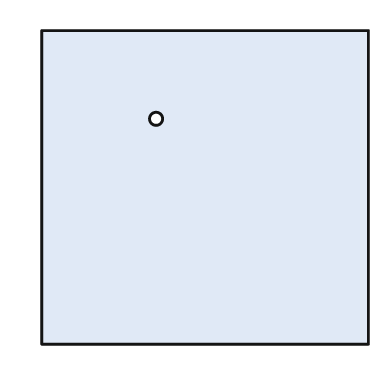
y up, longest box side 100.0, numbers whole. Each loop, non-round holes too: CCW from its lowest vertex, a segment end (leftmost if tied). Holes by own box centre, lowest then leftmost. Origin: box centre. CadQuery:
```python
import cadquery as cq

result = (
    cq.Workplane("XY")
    .moveTo(-50.0, -48.0)
    .lineTo(50.0, -48.0)
    .lineTo(50.0, 48.0)
    .lineTo(-50.0, 48.0)
    .close()
    .moveTo(-15.0, 21.0)
    .circle(2.0)
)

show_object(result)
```